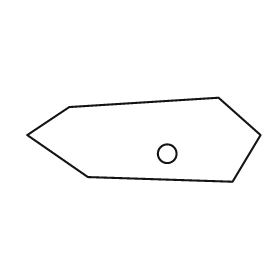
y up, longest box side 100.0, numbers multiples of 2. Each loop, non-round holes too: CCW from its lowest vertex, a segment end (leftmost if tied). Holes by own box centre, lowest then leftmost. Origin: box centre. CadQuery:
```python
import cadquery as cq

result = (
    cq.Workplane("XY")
    .moveTo(38.0, -18.0)
    .lineTo(50.0, 2.0)
    .lineTo(32.0, 18.0)
    .lineTo(-32.0, 14.0)
    .lineTo(-50.0, 2.0)
    .lineTo(-24.0, -16.0)
    .close()
    .moveTo(10.0, -6.0)
    .circle(4.0)
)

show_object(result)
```